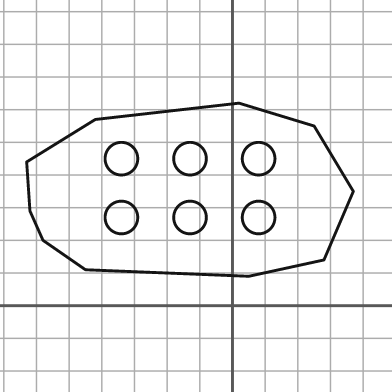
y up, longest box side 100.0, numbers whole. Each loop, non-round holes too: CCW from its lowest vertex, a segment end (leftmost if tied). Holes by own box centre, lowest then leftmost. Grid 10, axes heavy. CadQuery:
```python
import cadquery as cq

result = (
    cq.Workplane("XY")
    .moveTo(5.0, 9.0)
    .lineTo(28.0, 14.0)
    .lineTo(37.0, 35.0)
    .lineTo(25.0, 55.0)
    .lineTo(2.0, 62.0)
    .lineTo(-42.0, 57.0)
    .lineTo(-63.0, 44.0)
    .lineTo(-62.0, 29.0)
    .lineTo(-58.0, 20.0)
    .lineTo(-45.0, 11.0)
    .close()
    .moveTo(-34.0, 27.0)
    .circle(5.0)
    .moveTo(-13.0, 27.0)
    .circle(5.0)
    .moveTo(8.0, 27.0)
    .circle(5.0)
    .moveTo(-34.0, 45.0)
    .circle(5.0)
    .moveTo(-13.0, 45.0)
    .circle(5.0)
    .moveTo(8.0, 45.0)
    .circle(5.0)
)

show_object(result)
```